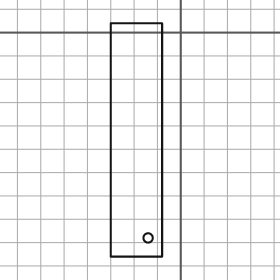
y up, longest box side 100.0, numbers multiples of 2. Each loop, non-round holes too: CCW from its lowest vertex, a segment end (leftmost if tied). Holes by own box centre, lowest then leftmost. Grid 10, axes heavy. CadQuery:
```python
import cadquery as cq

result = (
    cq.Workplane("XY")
    .moveTo(-30.0, -96.0)
    .lineTo(-8.0, -96.0)
    .lineTo(-8.0, 4.0)
    .lineTo(-30.0, 4.0)
    .close()
    .moveTo(-14.0, -88.0)
    .circle(2.0)
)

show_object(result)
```